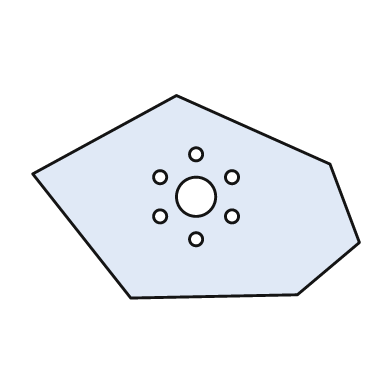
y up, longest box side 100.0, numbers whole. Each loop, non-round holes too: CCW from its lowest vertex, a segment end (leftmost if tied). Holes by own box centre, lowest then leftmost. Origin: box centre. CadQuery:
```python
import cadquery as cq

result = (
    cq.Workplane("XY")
    .moveTo(-20.0, -31.0)
    .lineTo(31.0, -30.0)
    .lineTo(50.0, -14.0)
    .lineTo(41.0, 10.0)
    .lineTo(-6.0, 31.0)
    .lineTo(-50.0, 7.0)
    .close()
    .moveTo(0.0, -13.0)
    .circle(2.0)
    .moveTo(-11.0, -6.0)
    .circle(2.0)
    .moveTo(11.0, -6.0)
    .circle(2.0)
    .moveTo(0.0, 0.0)
    .circle(6.0)
    .moveTo(-11.0, 6.0)
    .circle(2.0)
    .moveTo(11.0, 6.0)
    .circle(2.0)
    .moveTo(0.0, 13.0)
    .circle(2.0)
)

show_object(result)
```